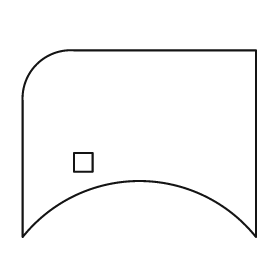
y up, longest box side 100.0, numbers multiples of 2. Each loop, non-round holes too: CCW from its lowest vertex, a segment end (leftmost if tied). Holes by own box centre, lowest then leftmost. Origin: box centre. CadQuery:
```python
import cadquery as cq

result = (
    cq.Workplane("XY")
    .moveTo(-50.0, -40.0)
    .threePointArc((0.0, -16.0), (50.0, -40.0))
    .lineTo(50.0, 40.0)
    .lineTo(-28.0, 40.0)
    .threePointArc((-44.0, 34.0), (-50.0, 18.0))
    .close()
    .moveTo(-28.0, -12.0)
    .lineTo(-20.0, -12.0)
    .lineTo(-20.0, -4.0)
    .lineTo(-28.0, -4.0)
    .close()
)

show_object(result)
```